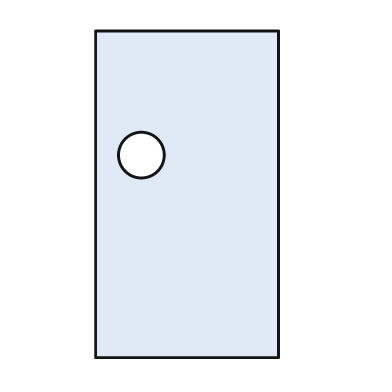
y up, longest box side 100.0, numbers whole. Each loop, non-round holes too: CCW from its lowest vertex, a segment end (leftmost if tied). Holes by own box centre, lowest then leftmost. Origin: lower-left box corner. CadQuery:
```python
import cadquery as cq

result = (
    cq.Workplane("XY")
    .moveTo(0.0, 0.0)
    .lineTo(56.0, 0.0)
    .lineTo(56.0, 100.0)
    .lineTo(0.0, 100.0)
    .close()
    .moveTo(14.0, 62.0)
    .circle(7.0)
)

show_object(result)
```